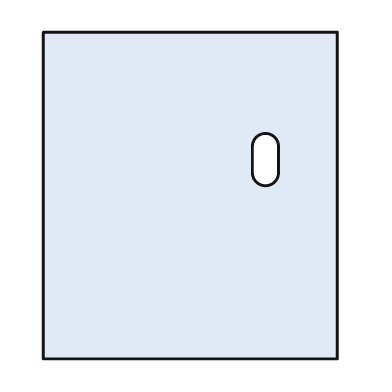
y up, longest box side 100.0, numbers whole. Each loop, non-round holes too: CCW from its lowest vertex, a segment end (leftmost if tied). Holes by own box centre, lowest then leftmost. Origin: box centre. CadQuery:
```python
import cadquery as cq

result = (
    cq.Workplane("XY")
    .moveTo(-45.0, -50.0)
    .lineTo(45.0, -50.0)
    .lineTo(45.0, 50.0)
    .lineTo(-45.0, 50.0)
    .close()
    .moveTo(19.0, 7.0)
    .threePointArc((23.0, 3.0), (27.0, 7.0))
    .lineTo(27.0, 15.0)
    .threePointArc((23.0, 19.0), (19.0, 15.0))
    .close()
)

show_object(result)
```